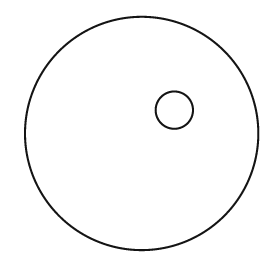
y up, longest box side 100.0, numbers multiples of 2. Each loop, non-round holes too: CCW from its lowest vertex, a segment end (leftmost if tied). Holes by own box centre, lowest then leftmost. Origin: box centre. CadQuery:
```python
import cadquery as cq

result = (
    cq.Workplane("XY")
    .moveTo(0.0, 0.0)
    .circle(50.0)
    .moveTo(14.0, 10.0)
    .circle(8.0)
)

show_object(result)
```